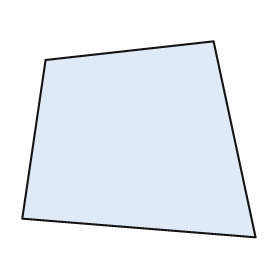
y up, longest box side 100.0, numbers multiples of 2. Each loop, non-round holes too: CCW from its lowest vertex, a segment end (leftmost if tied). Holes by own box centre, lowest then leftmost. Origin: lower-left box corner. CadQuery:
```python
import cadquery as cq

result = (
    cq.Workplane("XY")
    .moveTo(100.0, 0.0)
    .lineTo(82.0, 84.0)
    .lineTo(10.0, 76.0)
    .lineTo(0.0, 8.0)
    .close()
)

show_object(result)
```